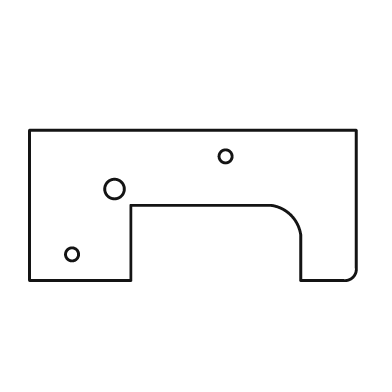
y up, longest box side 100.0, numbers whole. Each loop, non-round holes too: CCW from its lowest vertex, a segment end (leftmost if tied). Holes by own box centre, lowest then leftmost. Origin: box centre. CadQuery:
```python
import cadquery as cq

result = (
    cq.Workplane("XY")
    .moveTo(-50.0, -23.0)
    .lineTo(-19.0, -23.0)
    .lineTo(-19.0, 0.0)
    .lineTo(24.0, 0.0)
    .threePointArc((30.0, -3.0), (33.0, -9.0))
    .lineTo(33.0, -23.0)
    .lineTo(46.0, -23.0)
    .threePointArc((49.0, -22.0), (50.0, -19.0))
    .lineTo(50.0, 23.0)
    .lineTo(-50.0, 23.0)
    .close()
    .moveTo(-37.0, -15.0)
    .circle(2.0)
    .moveTo(-24.0, 5.0)
    .circle(3.0)
    .moveTo(10.0, 15.0)
    .circle(2.0)
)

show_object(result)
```